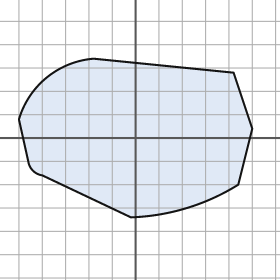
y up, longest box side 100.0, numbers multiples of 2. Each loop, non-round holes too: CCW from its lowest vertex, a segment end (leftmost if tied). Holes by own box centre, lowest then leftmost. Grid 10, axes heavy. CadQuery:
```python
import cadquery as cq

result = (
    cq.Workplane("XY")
    .moveTo(-2.0, -34.0)
    .threePointArc((22.0, -30.0), (44.0, -20.0))
    .lineTo(50.0, 4.0)
    .lineTo(42.0, 28.0)
    .lineTo(-18.0, 34.0)
    .threePointArc((-38.0, 26.0), (-50.0, 8.0))
    .lineTo(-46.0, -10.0)
    .threePointArc((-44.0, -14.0), (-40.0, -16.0))
    .close()
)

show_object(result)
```